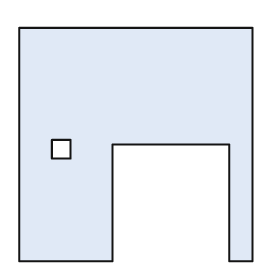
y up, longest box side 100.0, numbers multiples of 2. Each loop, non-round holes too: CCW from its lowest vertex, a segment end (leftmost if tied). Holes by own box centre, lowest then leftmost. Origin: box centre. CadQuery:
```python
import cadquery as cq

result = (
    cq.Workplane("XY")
    .moveTo(-50.0, -50.0)
    .lineTo(-10.0, -50.0)
    .lineTo(-10.0, 0.0)
    .lineTo(40.0, 0.0)
    .lineTo(40.0, -50.0)
    .lineTo(50.0, -50.0)
    .lineTo(50.0, 50.0)
    .lineTo(-50.0, 50.0)
    .close()
    .moveTo(-36.0, -6.0)
    .lineTo(-28.0, -6.0)
    .lineTo(-28.0, 2.0)
    .lineTo(-36.0, 2.0)
    .close()
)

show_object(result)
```